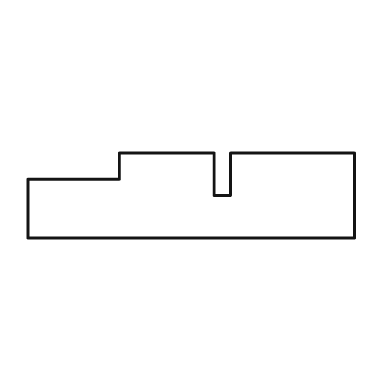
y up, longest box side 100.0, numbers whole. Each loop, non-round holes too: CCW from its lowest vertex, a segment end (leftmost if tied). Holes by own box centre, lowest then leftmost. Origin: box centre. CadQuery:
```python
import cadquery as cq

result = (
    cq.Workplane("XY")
    .moveTo(-50.0, -13.0)
    .lineTo(50.0, -13.0)
    .lineTo(50.0, 13.0)
    .lineTo(12.0, 13.0)
    .lineTo(12.0, 0.0)
    .lineTo(7.0, 0.0)
    .lineTo(7.0, 13.0)
    .lineTo(-22.0, 13.0)
    .lineTo(-22.0, 5.0)
    .lineTo(-50.0, 5.0)
    .close()
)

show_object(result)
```